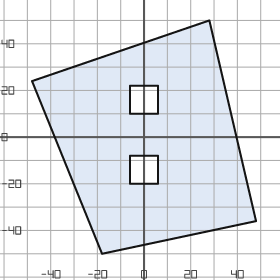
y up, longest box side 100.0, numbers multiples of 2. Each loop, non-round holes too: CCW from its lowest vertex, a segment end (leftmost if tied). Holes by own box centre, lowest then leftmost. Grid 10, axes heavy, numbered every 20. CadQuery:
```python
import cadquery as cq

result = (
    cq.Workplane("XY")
    .moveTo(-18.0, -50.0)
    .lineTo(48.0, -36.0)
    .lineTo(28.0, 50.0)
    .lineTo(-48.0, 24.0)
    .close()
    .moveTo(-6.0, -20.0)
    .lineTo(6.0, -20.0)
    .lineTo(6.0, -8.0)
    .lineTo(-6.0, -8.0)
    .close()
    .moveTo(-6.0, 10.0)
    .lineTo(6.0, 10.0)
    .lineTo(6.0, 22.0)
    .lineTo(-6.0, 22.0)
    .close()
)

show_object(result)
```